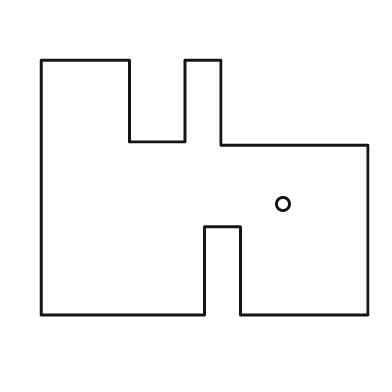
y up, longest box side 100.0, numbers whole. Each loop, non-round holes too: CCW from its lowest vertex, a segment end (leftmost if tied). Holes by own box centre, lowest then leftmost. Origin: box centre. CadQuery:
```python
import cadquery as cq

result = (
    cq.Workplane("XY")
    .moveTo(-50.0, -39.0)
    .lineTo(0.0, -39.0)
    .lineTo(0.0, -12.0)
    .lineTo(11.0, -12.0)
    .lineTo(11.0, -39.0)
    .lineTo(50.0, -39.0)
    .lineTo(50.0, 13.0)
    .lineTo(5.0, 13.0)
    .lineTo(5.0, 39.0)
    .lineTo(-6.0, 39.0)
    .lineTo(-6.0, 14.0)
    .lineTo(-23.0, 14.0)
    .lineTo(-23.0, 39.0)
    .lineTo(-50.0, 39.0)
    .close()
    .moveTo(24.0, -5.0)
    .circle(2.0)
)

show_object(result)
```